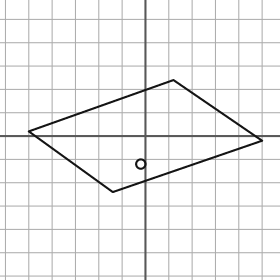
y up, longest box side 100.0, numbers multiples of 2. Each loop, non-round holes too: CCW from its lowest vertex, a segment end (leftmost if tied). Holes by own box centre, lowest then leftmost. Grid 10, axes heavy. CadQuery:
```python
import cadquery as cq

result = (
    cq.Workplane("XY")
    .moveTo(-14.0, -24.0)
    .lineTo(50.0, -2.0)
    .lineTo(12.0, 24.0)
    .lineTo(-50.0, 2.0)
    .close()
    .moveTo(-2.0, -12.0)
    .circle(2.0)
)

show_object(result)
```